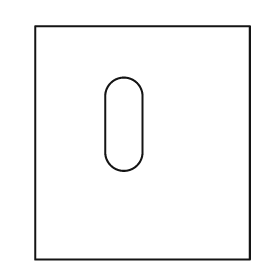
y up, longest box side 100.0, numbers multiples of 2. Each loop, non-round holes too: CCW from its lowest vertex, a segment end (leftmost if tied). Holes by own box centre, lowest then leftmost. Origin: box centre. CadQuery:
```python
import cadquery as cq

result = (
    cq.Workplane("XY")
    .moveTo(-46.0, -50.0)
    .lineTo(46.0, -50.0)
    .lineTo(46.0, 50.0)
    .lineTo(-46.0, 50.0)
    .close()
    .moveTo(-16.0, -4.0)
    .threePointArc((-8.0, -12.0), (0.0, -4.0))
    .lineTo(0.0, 20.0)
    .threePointArc((-8.0, 28.0), (-16.0, 20.0))
    .close()
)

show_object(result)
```